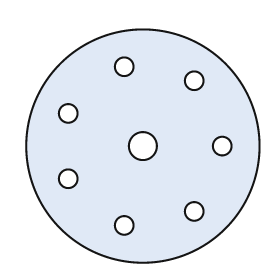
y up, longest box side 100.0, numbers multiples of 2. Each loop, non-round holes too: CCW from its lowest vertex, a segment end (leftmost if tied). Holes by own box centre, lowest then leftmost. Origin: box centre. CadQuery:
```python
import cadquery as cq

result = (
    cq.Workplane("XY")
    .moveTo(0.0, 0.0)
    .circle(50.0)
    .moveTo(-8.0, -34.0)
    .circle(4.0)
    .moveTo(22.0, -28.0)
    .circle(4.0)
    .moveTo(-32.0, -14.0)
    .circle(4.0)
    .moveTo(0.0, 0.0)
    .circle(6.0)
    .moveTo(34.0, 0.0)
    .circle(4.0)
    .moveTo(-32.0, 14.0)
    .circle(4.0)
    .moveTo(22.0, 28.0)
    .circle(4.0)
    .moveTo(-8.0, 34.0)
    .circle(4.0)
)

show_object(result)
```